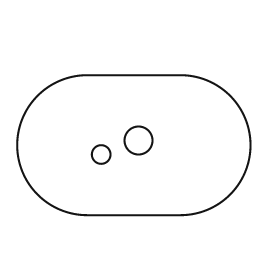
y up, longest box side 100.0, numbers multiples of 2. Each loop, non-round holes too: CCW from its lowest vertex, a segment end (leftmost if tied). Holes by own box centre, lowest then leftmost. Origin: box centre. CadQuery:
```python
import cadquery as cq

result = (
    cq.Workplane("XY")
    .moveTo(-20.0, -30.0)
    .lineTo(20.0, -30.0)
    .threePointArc((50.0, 0.0), (20.0, 30.0))
    .lineTo(-20.0, 30.0)
    .threePointArc((-50.0, 0.0), (-20.0, -30.0))
    .close()
    .moveTo(-14.0, -4.0)
    .circle(4.0)
    .moveTo(2.0, 2.0)
    .circle(6.0)
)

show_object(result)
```